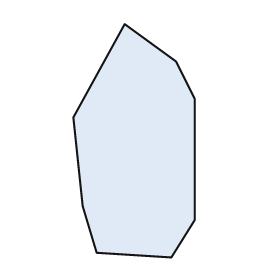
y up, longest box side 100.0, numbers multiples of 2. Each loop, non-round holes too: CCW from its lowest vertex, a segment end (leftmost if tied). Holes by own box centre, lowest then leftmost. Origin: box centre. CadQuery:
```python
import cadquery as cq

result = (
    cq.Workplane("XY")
    .moveTo(16.0, -50.0)
    .lineTo(26.0, -34.0)
    .lineTo(26.0, 18.0)
    .lineTo(18.0, 34.0)
    .lineTo(-4.0, 50.0)
    .lineTo(-26.0, 10.0)
    .lineTo(-22.0, -28.0)
    .lineTo(-16.0, -48.0)
    .close()
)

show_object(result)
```